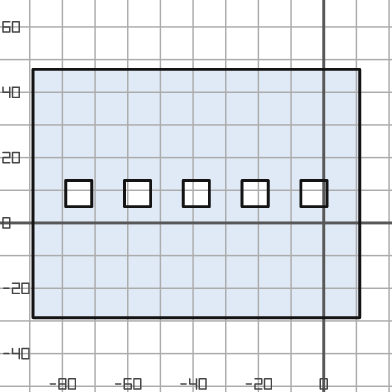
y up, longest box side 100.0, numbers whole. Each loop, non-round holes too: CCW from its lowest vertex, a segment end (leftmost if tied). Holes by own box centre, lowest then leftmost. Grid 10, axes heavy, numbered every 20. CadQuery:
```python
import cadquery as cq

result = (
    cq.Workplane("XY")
    .moveTo(-89.0, -29.0)
    .lineTo(11.0, -29.0)
    .lineTo(11.0, 47.0)
    .lineTo(-89.0, 47.0)
    .close()
    .moveTo(-79.0, 5.0)
    .lineTo(-71.0, 5.0)
    .lineTo(-71.0, 13.0)
    .lineTo(-79.0, 13.0)
    .close()
    .moveTo(-61.0, 5.0)
    .lineTo(-53.0, 5.0)
    .lineTo(-53.0, 13.0)
    .lineTo(-61.0, 13.0)
    .close()
    .moveTo(-43.0, 5.0)
    .lineTo(-35.0, 5.0)
    .lineTo(-35.0, 13.0)
    .lineTo(-43.0, 13.0)
    .close()
    .moveTo(-25.0, 5.0)
    .lineTo(-17.0, 5.0)
    .lineTo(-17.0, 13.0)
    .lineTo(-25.0, 13.0)
    .close()
    .moveTo(-7.0, 5.0)
    .lineTo(1.0, 5.0)
    .lineTo(1.0, 13.0)
    .lineTo(-7.0, 13.0)
    .close()
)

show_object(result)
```